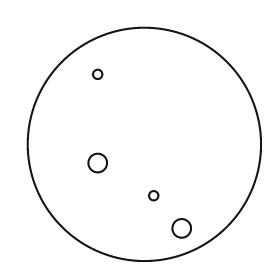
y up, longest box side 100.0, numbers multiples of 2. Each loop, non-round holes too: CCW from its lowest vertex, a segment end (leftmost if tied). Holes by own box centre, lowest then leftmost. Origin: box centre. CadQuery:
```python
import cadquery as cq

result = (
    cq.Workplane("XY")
    .moveTo(0.0, 0.0)
    .circle(50.0)
    .moveTo(16.0, -36.0)
    .circle(4.0)
    .moveTo(4.0, -22.0)
    .circle(2.0)
    .moveTo(-20.0, -8.0)
    .circle(4.0)
    .moveTo(-20.0, 30.0)
    .circle(2.0)
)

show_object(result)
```